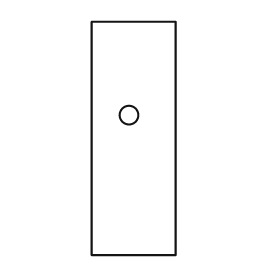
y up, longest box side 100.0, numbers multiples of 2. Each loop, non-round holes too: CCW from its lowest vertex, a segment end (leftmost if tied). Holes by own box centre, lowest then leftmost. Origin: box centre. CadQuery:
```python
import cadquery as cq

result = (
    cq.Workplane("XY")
    .moveTo(-18.0, -50.0)
    .lineTo(18.0, -50.0)
    .lineTo(18.0, 50.0)
    .lineTo(-18.0, 50.0)
    .close()
    .moveTo(-2.0, 10.0)
    .circle(4.0)
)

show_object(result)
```